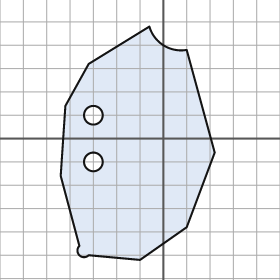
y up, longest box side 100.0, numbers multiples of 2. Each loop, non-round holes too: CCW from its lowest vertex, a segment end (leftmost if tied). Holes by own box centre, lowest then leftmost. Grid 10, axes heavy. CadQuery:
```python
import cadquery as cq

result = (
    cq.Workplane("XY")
    .moveTo(-10.0, -52.0)
    .lineTo(10.0, -38.0)
    .lineTo(22.0, -6.0)
    .lineTo(10.0, 38.0)
    .threePointArc((0.0, 40.0), (-6.0, 48.0))
    .lineTo(-32.0, 32.0)
    .lineTo(-42.0, 14.0)
    .lineTo(-44.0, -16.0)
    .lineTo(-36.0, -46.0)
    .threePointArc((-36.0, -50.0), (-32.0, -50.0))
    .close()
    .moveTo(-30.0, -10.0)
    .circle(4.0)
    .moveTo(-30.0, 10.0)
    .circle(4.0)
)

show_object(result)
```